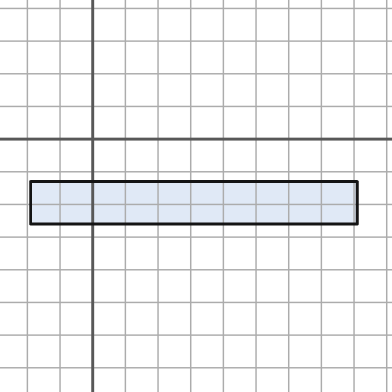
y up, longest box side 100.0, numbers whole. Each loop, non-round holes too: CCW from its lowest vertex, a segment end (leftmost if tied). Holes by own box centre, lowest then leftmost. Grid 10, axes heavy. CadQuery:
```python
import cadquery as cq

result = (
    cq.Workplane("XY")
    .moveTo(-19.0, -26.0)
    .lineTo(81.0, -26.0)
    .lineTo(81.0, -13.0)
    .lineTo(-19.0, -13.0)
    .close()
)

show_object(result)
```